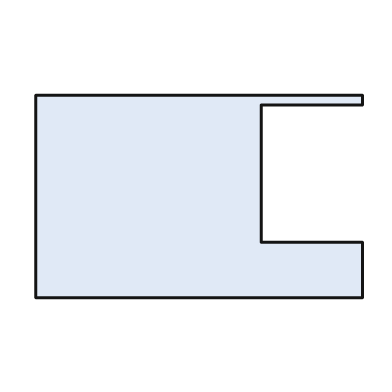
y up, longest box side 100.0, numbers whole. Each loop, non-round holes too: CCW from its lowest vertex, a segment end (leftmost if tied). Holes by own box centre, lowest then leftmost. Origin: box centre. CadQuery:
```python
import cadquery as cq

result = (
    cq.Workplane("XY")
    .moveTo(-50.0, -31.0)
    .lineTo(50.0, -31.0)
    .lineTo(50.0, -14.0)
    .lineTo(19.0, -14.0)
    .lineTo(19.0, 28.0)
    .lineTo(50.0, 28.0)
    .lineTo(50.0, 31.0)
    .lineTo(-50.0, 31.0)
    .close()
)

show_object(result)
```